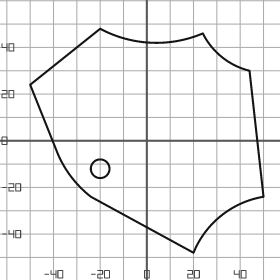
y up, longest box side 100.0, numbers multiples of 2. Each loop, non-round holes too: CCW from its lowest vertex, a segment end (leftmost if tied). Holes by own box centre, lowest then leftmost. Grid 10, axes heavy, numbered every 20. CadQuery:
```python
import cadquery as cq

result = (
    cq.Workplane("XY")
    .moveTo(20.0, -48.0)
    .threePointArc((32.0, -32.0), (50.0, -24.0))
    .lineTo(44.0, 30.0)
    .threePointArc((32.0, 36.0), (24.0, 46.0))
    .threePointArc((2.0, 42.0), (-20.0, 48.0))
    .lineTo(-50.0, 24.0)
    .lineTo(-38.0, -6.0)
    .threePointArc((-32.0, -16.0), (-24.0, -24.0))
    .close()
    .moveTo(-20.0, -12.0)
    .circle(4.0)
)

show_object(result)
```